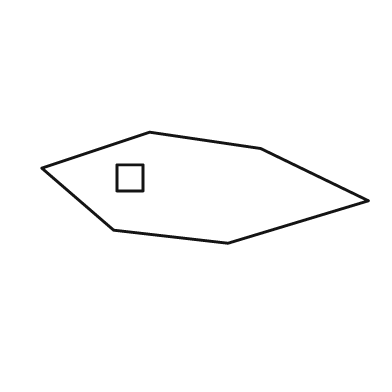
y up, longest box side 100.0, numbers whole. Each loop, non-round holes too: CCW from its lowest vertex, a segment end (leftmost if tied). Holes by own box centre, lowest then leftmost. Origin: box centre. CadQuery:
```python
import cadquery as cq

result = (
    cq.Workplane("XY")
    .moveTo(7.0, -17.0)
    .lineTo(50.0, -4.0)
    .lineTo(17.0, 12.0)
    .lineTo(-17.0, 17.0)
    .lineTo(-50.0, 6.0)
    .lineTo(-28.0, -13.0)
    .close()
    .moveTo(-27.0, -1.0)
    .lineTo(-19.0, -1.0)
    .lineTo(-19.0, 7.0)
    .lineTo(-27.0, 7.0)
    .close()
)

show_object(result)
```